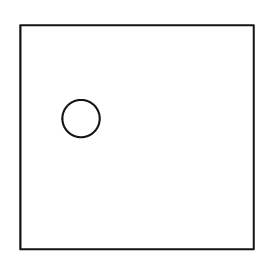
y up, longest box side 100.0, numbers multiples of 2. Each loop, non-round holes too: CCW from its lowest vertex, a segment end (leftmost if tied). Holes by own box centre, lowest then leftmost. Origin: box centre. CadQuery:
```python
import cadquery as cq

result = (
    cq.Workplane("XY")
    .moveTo(-50.0, -48.0)
    .lineTo(50.0, -48.0)
    .lineTo(50.0, 48.0)
    .lineTo(-50.0, 48.0)
    .close()
    .moveTo(-24.0, 8.0)
    .circle(8.0)
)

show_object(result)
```